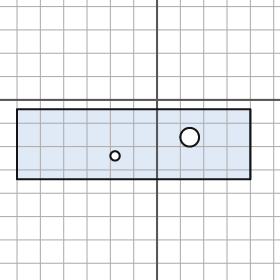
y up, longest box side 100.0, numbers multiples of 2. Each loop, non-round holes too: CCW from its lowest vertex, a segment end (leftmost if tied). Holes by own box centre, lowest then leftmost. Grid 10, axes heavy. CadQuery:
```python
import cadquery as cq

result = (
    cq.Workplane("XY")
    .moveTo(-60.0, -34.0)
    .lineTo(40.0, -34.0)
    .lineTo(40.0, -4.0)
    .lineTo(-60.0, -4.0)
    .close()
    .moveTo(-18.0, -24.0)
    .circle(2.0)
    .moveTo(14.0, -16.0)
    .circle(4.0)
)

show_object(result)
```